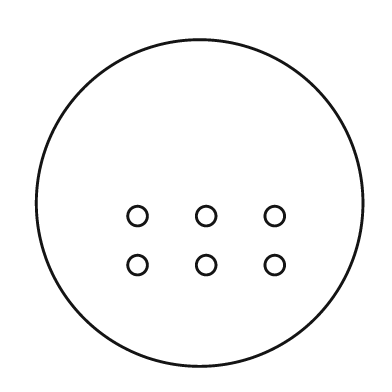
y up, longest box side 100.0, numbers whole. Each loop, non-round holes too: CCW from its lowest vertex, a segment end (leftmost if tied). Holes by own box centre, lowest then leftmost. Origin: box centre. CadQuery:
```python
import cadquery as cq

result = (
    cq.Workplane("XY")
    .moveTo(0.0, 0.0)
    .circle(50.0)
    .moveTo(-19.0, -19.0)
    .circle(3.0)
    .moveTo(2.0, -19.0)
    .circle(3.0)
    .moveTo(23.0, -19.0)
    .circle(3.0)
    .moveTo(-19.0, -4.0)
    .circle(3.0)
    .moveTo(2.0, -4.0)
    .circle(3.0)
    .moveTo(23.0, -4.0)
    .circle(3.0)
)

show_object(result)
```